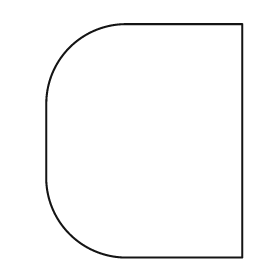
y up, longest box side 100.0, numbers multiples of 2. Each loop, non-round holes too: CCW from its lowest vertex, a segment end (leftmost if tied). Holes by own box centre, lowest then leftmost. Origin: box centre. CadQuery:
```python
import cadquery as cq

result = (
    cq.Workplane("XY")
    .moveTo(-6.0, -50.0)
    .lineTo(42.0, -50.0)
    .lineTo(42.0, 50.0)
    .lineTo(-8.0, 50.0)
    .threePointArc((-32.0, 40.0), (-42.0, 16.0))
    .lineTo(-42.0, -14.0)
    .threePointArc((-32.0, -40.0), (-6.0, -50.0))
    .close()
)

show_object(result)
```